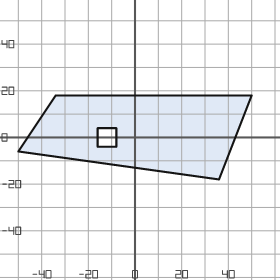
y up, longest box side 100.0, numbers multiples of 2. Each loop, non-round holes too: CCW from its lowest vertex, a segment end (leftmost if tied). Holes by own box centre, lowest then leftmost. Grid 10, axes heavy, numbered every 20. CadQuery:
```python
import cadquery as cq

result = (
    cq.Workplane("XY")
    .moveTo(36.0, -18.0)
    .lineTo(50.0, 18.0)
    .lineTo(-34.0, 18.0)
    .lineTo(-50.0, -6.0)
    .close()
    .moveTo(-16.0, -4.0)
    .lineTo(-8.0, -4.0)
    .lineTo(-8.0, 4.0)
    .lineTo(-16.0, 4.0)
    .close()
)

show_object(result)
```